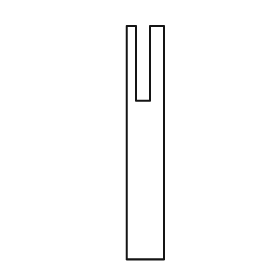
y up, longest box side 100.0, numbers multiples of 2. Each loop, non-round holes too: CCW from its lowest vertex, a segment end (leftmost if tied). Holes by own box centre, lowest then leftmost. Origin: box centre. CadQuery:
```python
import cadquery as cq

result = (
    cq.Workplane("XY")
    .moveTo(-8.0, -50.0)
    .lineTo(8.0, -50.0)
    .lineTo(8.0, 50.0)
    .lineTo(2.0, 50.0)
    .lineTo(2.0, 18.0)
    .lineTo(-4.0, 18.0)
    .lineTo(-4.0, 50.0)
    .lineTo(-8.0, 50.0)
    .close()
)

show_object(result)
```